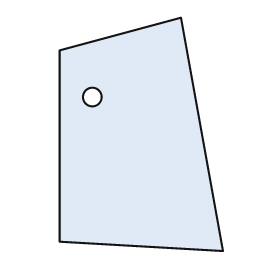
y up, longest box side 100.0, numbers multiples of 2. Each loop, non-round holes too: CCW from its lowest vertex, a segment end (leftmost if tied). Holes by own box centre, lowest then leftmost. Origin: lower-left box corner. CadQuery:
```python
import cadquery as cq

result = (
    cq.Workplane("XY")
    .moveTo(70.0, 0.0)
    .lineTo(52.0, 100.0)
    .lineTo(0.0, 86.0)
    .lineTo(0.0, 4.0)
    .close()
    .moveTo(14.0, 66.0)
    .circle(4.0)
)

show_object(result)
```